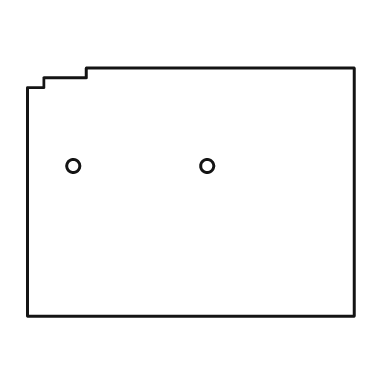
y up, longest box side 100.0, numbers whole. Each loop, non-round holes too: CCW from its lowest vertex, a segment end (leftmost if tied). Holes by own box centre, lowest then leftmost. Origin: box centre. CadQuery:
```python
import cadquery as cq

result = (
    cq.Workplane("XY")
    .moveTo(-50.0, -38.0)
    .lineTo(50.0, -38.0)
    .lineTo(50.0, 38.0)
    .lineTo(-32.0, 38.0)
    .lineTo(-32.0, 35.0)
    .lineTo(-45.0, 35.0)
    .lineTo(-45.0, 32.0)
    .lineTo(-50.0, 32.0)
    .close()
    .moveTo(-36.0, 8.0)
    .circle(2.0)
    .moveTo(5.0, 8.0)
    .circle(2.0)
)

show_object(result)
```